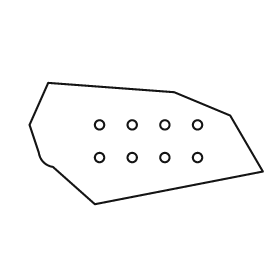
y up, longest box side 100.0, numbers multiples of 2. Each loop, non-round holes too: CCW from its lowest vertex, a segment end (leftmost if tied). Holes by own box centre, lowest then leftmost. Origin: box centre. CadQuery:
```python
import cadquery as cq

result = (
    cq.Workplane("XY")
    .moveTo(-22.0, -26.0)
    .lineTo(50.0, -12.0)
    .lineTo(36.0, 12.0)
    .lineTo(12.0, 22.0)
    .lineTo(-42.0, 26.0)
    .lineTo(-50.0, 8.0)
    .lineTo(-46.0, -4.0)
    .threePointArc((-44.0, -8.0), (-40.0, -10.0))
    .close()
    .moveTo(-20.0, -6.0)
    .circle(2.0)
    .moveTo(-6.0, -6.0)
    .circle(2.0)
    .moveTo(8.0, -6.0)
    .circle(2.0)
    .moveTo(22.0, -6.0)
    .circle(2.0)
    .moveTo(-20.0, 8.0)
    .circle(2.0)
    .moveTo(-6.0, 8.0)
    .circle(2.0)
    .moveTo(8.0, 8.0)
    .circle(2.0)
    .moveTo(22.0, 8.0)
    .circle(2.0)
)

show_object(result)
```